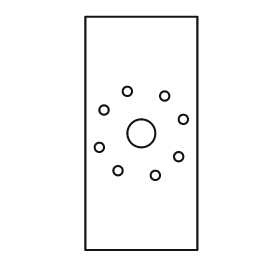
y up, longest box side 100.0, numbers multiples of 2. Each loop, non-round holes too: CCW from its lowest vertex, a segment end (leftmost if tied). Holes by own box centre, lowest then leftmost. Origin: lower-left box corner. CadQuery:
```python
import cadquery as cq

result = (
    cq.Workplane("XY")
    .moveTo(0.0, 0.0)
    .lineTo(48.0, 0.0)
    .lineTo(48.0, 100.0)
    .lineTo(0.0, 100.0)
    .close()
    .moveTo(30.0, 32.0)
    .circle(2.0)
    .moveTo(14.0, 34.0)
    .circle(2.0)
    .moveTo(40.0, 40.0)
    .circle(2.0)
    .moveTo(6.0, 44.0)
    .circle(2.0)
    .moveTo(24.0, 50.0)
    .circle(6.0)
    .moveTo(42.0, 56.0)
    .circle(2.0)
    .moveTo(8.0, 60.0)
    .circle(2.0)
    .moveTo(34.0, 66.0)
    .circle(2.0)
    .moveTo(18.0, 68.0)
    .circle(2.0)
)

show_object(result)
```